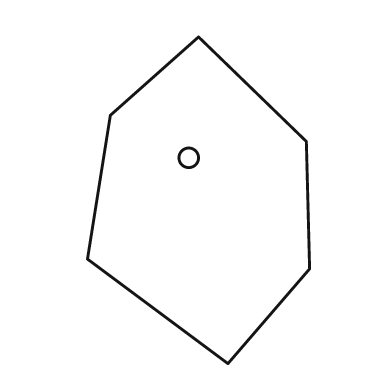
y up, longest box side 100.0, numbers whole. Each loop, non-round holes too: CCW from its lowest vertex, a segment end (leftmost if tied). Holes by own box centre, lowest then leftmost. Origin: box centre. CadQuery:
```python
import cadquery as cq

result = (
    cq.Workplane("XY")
    .moveTo(9.0, -50.0)
    .lineTo(34.0, -21.0)
    .lineTo(33.0, 18.0)
    .lineTo(0.0, 50.0)
    .lineTo(-27.0, 26.0)
    .lineTo(-34.0, -18.0)
    .close()
    .moveTo(-3.0, 13.0)
    .circle(3.0)
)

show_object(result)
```